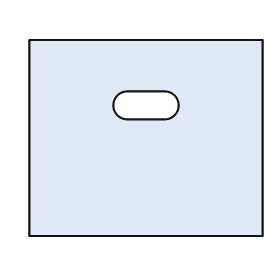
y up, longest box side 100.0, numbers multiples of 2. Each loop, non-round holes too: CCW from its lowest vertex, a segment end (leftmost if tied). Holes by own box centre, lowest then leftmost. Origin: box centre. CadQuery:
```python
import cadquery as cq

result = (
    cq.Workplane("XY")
    .moveTo(-50.0, -42.0)
    .lineTo(50.0, -42.0)
    .lineTo(50.0, 42.0)
    .lineTo(-50.0, 42.0)
    .close()
    .moveTo(-8.0, 8.0)
    .lineTo(8.0, 8.0)
    .threePointArc((14.0, 14.0), (8.0, 20.0))
    .lineTo(-8.0, 20.0)
    .threePointArc((-14.0, 14.0), (-8.0, 8.0))
    .close()
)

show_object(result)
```